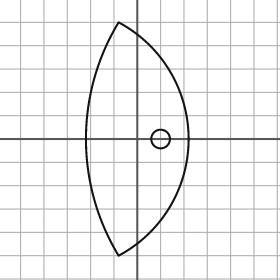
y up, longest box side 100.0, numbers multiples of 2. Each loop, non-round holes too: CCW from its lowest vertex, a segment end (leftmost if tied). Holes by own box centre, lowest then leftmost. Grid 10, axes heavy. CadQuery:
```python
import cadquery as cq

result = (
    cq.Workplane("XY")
    .moveTo(-8.0, -50.0)
    .threePointArc((22.0, 0.0), (-8.0, 50.0))
    .threePointArc((-22.0, 0.0), (-8.0, -50.0))
    .close()
    .moveTo(10.0, 0.0)
    .circle(4.0)
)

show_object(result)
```